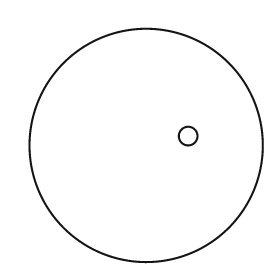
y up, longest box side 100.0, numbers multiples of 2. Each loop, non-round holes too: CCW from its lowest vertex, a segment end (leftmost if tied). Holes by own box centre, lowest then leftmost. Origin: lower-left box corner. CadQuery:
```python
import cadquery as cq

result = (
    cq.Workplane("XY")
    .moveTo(50.0, 50.0)
    .circle(50.0)
    .moveTo(68.0, 54.0)
    .circle(4.0)
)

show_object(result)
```